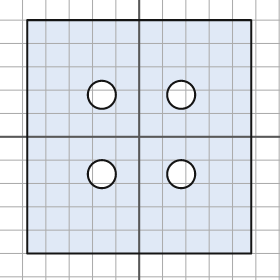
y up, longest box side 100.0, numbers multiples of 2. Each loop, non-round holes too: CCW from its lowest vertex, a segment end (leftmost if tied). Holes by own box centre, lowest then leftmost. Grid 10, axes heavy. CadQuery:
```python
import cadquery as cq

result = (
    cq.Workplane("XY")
    .moveTo(-48.0, -50.0)
    .lineTo(48.0, -50.0)
    .lineTo(48.0, 50.0)
    .lineTo(-48.0, 50.0)
    .close()
    .moveTo(-16.0, -16.0)
    .circle(6.0)
    .moveTo(18.0, -16.0)
    .circle(6.0)
    .moveTo(-16.0, 18.0)
    .circle(6.0)
    .moveTo(18.0, 18.0)
    .circle(6.0)
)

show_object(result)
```